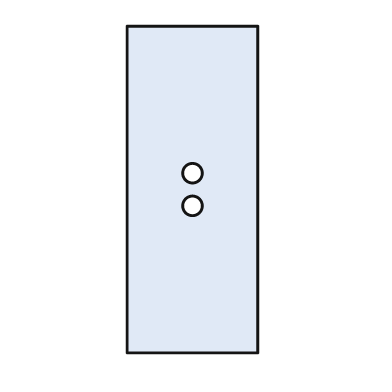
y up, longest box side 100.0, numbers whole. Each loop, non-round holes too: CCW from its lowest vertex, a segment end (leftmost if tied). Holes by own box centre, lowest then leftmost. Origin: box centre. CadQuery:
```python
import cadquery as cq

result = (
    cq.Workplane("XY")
    .moveTo(-20.0, -50.0)
    .lineTo(20.0, -50.0)
    .lineTo(20.0, 50.0)
    .lineTo(-20.0, 50.0)
    .close()
    .moveTo(0.0, -5.0)
    .circle(3.0)
    .moveTo(0.0, 5.0)
    .circle(3.0)
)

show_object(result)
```